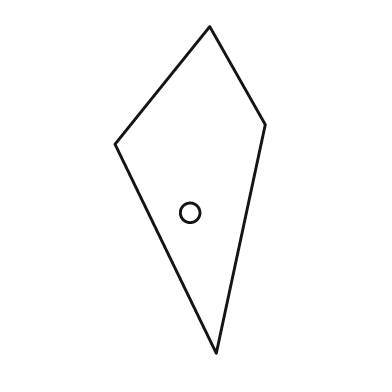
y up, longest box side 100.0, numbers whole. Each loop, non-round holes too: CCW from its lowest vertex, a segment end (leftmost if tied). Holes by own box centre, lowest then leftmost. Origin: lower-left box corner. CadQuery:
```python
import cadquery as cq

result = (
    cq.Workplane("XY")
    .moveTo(31.0, 0.0)
    .lineTo(46.0, 70.0)
    .lineTo(29.0, 100.0)
    .lineTo(0.0, 64.0)
    .close()
    .moveTo(23.0, 43.0)
    .circle(3.0)
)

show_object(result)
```